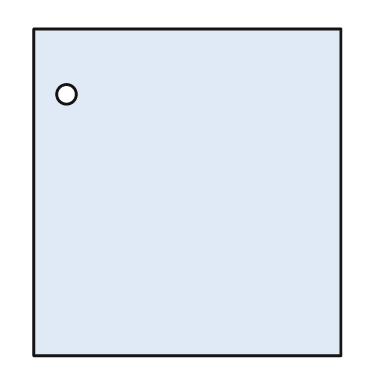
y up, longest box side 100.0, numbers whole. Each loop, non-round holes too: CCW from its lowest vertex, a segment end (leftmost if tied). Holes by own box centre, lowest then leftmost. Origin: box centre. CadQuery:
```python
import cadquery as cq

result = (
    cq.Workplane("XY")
    .moveTo(-47.0, -50.0)
    .lineTo(47.0, -50.0)
    .lineTo(47.0, 50.0)
    .lineTo(-47.0, 50.0)
    .close()
    .moveTo(-37.0, 30.0)
    .circle(3.0)
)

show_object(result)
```